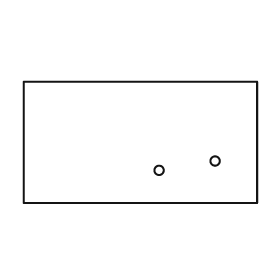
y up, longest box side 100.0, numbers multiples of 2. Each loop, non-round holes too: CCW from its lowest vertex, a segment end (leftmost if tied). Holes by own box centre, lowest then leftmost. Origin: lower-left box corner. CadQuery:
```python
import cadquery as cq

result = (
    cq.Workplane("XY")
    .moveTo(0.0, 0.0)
    .lineTo(100.0, 0.0)
    .lineTo(100.0, 52.0)
    .lineTo(0.0, 52.0)
    .close()
    .moveTo(58.0, 14.0)
    .circle(2.0)
    .moveTo(82.0, 18.0)
    .circle(2.0)
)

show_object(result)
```